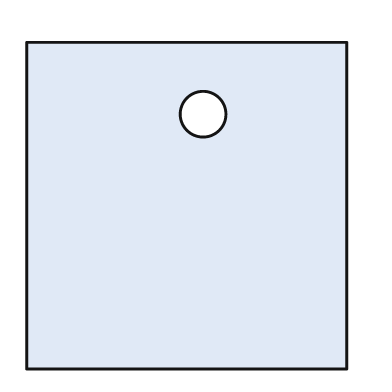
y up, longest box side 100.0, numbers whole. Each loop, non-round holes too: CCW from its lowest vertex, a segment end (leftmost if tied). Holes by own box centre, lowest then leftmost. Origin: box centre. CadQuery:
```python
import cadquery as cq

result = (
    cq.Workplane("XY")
    .moveTo(-49.0, -50.0)
    .lineTo(49.0, -50.0)
    .lineTo(49.0, 50.0)
    .lineTo(-49.0, 50.0)
    .close()
    .moveTo(5.0, 28.0)
    .circle(7.0)
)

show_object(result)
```